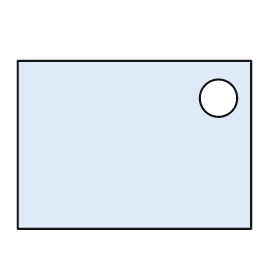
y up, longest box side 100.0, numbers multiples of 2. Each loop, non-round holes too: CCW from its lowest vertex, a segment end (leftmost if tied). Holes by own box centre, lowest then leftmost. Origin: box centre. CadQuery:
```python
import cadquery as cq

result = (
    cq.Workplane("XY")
    .moveTo(-50.0, -36.0)
    .lineTo(50.0, -36.0)
    .lineTo(50.0, 36.0)
    .lineTo(-50.0, 36.0)
    .close()
    .moveTo(36.0, 20.0)
    .circle(8.0)
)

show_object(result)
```